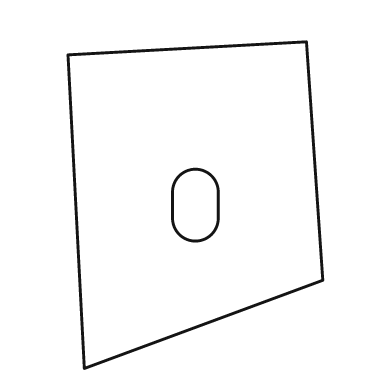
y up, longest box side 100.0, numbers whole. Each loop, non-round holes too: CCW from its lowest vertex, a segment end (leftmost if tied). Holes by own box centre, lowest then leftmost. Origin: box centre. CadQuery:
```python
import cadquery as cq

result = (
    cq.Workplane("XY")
    .moveTo(-34.0, -50.0)
    .lineTo(39.0, -23.0)
    .lineTo(34.0, 50.0)
    .lineTo(-39.0, 46.0)
    .close()
    .moveTo(-7.0, -4.0)
    .threePointArc((0.0, -11.0), (7.0, -4.0))
    .lineTo(7.0, 4.0)
    .threePointArc((0.0, 11.0), (-7.0, 4.0))
    .close()
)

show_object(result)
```